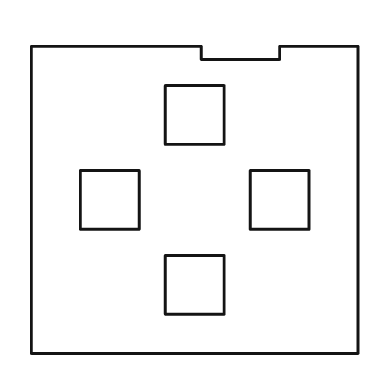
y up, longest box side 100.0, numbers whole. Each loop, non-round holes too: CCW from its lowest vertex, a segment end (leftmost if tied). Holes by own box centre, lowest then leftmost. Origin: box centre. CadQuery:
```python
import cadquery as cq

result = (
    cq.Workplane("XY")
    .moveTo(-50.0, -47.0)
    .lineTo(50.0, -47.0)
    .lineTo(50.0, 47.0)
    .lineTo(26.0, 47.0)
    .lineTo(26.0, 43.0)
    .lineTo(2.0, 43.0)
    .lineTo(2.0, 47.0)
    .lineTo(-50.0, 47.0)
    .close()
    .moveTo(-9.0, -35.0)
    .lineTo(9.0, -35.0)
    .lineTo(9.0, -17.0)
    .lineTo(-9.0, -17.0)
    .close()
    .moveTo(-35.0, -9.0)
    .lineTo(-17.0, -9.0)
    .lineTo(-17.0, 9.0)
    .lineTo(-35.0, 9.0)
    .close()
    .moveTo(17.0, -9.0)
    .lineTo(35.0, -9.0)
    .lineTo(35.0, 9.0)
    .lineTo(17.0, 9.0)
    .close()
    .moveTo(-9.0, 17.0)
    .lineTo(9.0, 17.0)
    .lineTo(9.0, 35.0)
    .lineTo(-9.0, 35.0)
    .close()
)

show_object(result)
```